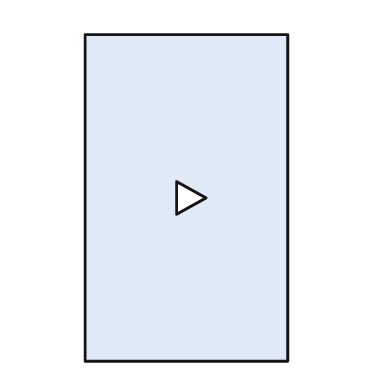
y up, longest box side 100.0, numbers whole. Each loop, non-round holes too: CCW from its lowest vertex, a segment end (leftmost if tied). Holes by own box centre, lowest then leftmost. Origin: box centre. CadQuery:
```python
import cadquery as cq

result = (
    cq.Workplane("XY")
    .moveTo(-31.0, -50.0)
    .lineTo(31.0, -50.0)
    .lineTo(31.0, 50.0)
    .lineTo(-31.0, 50.0)
    .close()
    .moveTo(-3.0, -5.0)
    .lineTo(6.0, 0.0)
    .lineTo(-3.0, 5.0)
    .close()
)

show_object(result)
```